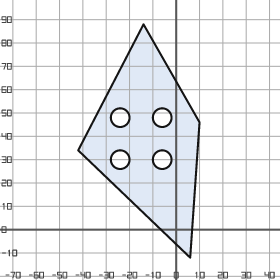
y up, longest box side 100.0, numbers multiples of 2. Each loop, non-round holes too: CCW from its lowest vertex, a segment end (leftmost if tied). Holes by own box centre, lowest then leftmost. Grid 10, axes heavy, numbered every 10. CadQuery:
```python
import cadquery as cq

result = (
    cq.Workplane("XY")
    .moveTo(6.0, -12.0)
    .lineTo(10.0, 46.0)
    .lineTo(-14.0, 88.0)
    .lineTo(-42.0, 34.0)
    .close()
    .moveTo(-24.0, 30.0)
    .circle(4.0)
    .moveTo(-6.0, 30.0)
    .circle(4.0)
    .moveTo(-24.0, 48.0)
    .circle(4.0)
    .moveTo(-6.0, 48.0)
    .circle(4.0)
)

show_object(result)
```